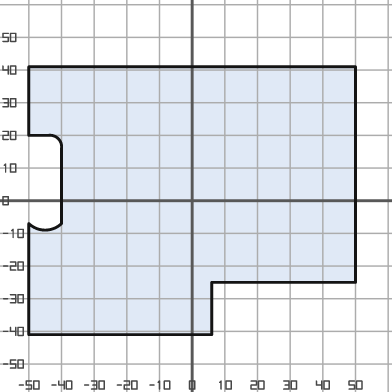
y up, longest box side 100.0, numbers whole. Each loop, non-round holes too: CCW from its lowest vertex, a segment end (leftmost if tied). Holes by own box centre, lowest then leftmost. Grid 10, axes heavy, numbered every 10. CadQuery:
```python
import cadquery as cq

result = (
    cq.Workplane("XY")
    .moveTo(-50.0, -41.0)
    .lineTo(6.0, -41.0)
    .lineTo(6.0, -25.0)
    .lineTo(50.0, -25.0)
    .lineTo(50.0, 41.0)
    .lineTo(-50.0, 41.0)
    .lineTo(-50.0, 20.0)
    .lineTo(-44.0, 20.0)
    .threePointArc((-41.0, 19.0), (-40.0, 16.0))
    .lineTo(-40.0, -7.0)
    .threePointArc((-45.0, -9.0), (-50.0, -7.0))
    .close()
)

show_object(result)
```